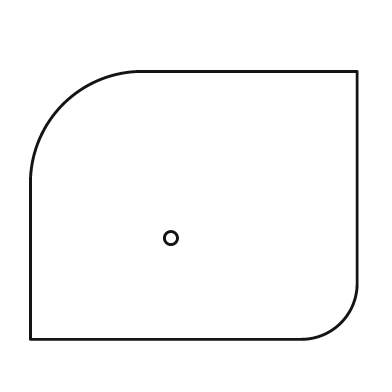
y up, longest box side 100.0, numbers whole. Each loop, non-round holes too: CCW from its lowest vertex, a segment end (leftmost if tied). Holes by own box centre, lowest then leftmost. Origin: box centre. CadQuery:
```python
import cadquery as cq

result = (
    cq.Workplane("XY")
    .moveTo(-50.0, -41.0)
    .lineTo(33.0, -41.0)
    .threePointArc((45.0, -36.0), (50.0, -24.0))
    .lineTo(50.0, 41.0)
    .lineTo(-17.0, 41.0)
    .threePointArc((-40.0, 31.0), (-50.0, 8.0))
    .close()
    .moveTo(-7.0, -10.0)
    .circle(2.0)
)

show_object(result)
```